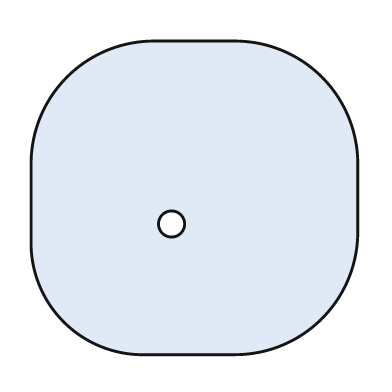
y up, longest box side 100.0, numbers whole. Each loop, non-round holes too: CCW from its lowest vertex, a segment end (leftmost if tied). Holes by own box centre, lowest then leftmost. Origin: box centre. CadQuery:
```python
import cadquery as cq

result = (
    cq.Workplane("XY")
    .moveTo(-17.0, -48.0)
    .lineTo(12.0, -48.0)
    .threePointArc((39.0, -37.0), (50.0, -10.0))
    .lineTo(50.0, 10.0)
    .threePointArc((39.0, 37.0), (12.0, 48.0))
    .lineTo(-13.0, 48.0)
    .threePointArc((-39.0, 37.0), (-50.0, 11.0))
    .lineTo(-50.0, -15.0)
    .threePointArc((-40.0, -38.0), (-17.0, -48.0))
    .close()
    .moveTo(-7.0, -8.0)
    .circle(4.0)
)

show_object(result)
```